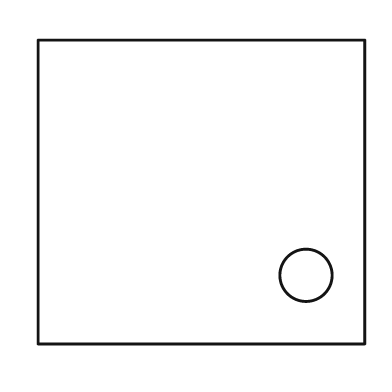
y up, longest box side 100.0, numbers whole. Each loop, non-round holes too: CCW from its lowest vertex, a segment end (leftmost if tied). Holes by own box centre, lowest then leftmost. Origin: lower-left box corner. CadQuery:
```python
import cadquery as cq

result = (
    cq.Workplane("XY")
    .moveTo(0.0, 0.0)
    .lineTo(100.0, 0.0)
    .lineTo(100.0, 93.0)
    .lineTo(0.0, 93.0)
    .close()
    .moveTo(82.0, 21.0)
    .circle(8.0)
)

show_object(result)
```